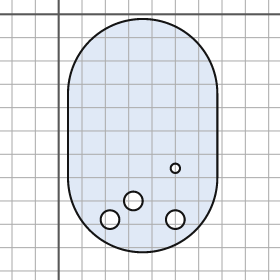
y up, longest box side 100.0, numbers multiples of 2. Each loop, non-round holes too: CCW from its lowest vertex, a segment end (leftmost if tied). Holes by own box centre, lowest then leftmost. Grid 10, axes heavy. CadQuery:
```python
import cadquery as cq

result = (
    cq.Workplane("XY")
    .moveTo(4.0, -70.0)
    .threePointArc((36.0, -102.0), (68.0, -70.0))
    .lineTo(68.0, -34.0)
    .threePointArc((36.0, -2.0), (4.0, -34.0))
    .close()
    .moveTo(22.0, -88.0)
    .circle(4.0)
    .moveTo(50.0, -88.0)
    .circle(4.0)
    .moveTo(32.0, -80.0)
    .circle(4.0)
    .moveTo(50.0, -66.0)
    .circle(2.0)
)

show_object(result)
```